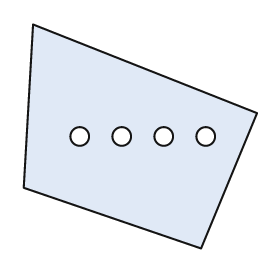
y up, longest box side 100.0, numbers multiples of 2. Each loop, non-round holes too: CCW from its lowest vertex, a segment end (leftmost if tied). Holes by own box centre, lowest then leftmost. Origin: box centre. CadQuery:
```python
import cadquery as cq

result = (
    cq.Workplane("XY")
    .moveTo(26.0, -48.0)
    .lineTo(50.0, 10.0)
    .lineTo(-46.0, 48.0)
    .lineTo(-50.0, -22.0)
    .close()
    .moveTo(-26.0, 0.0)
    .circle(4.0)
    .moveTo(-8.0, 0.0)
    .circle(4.0)
    .moveTo(10.0, 0.0)
    .circle(4.0)
    .moveTo(28.0, 0.0)
    .circle(4.0)
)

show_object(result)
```